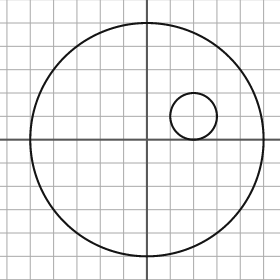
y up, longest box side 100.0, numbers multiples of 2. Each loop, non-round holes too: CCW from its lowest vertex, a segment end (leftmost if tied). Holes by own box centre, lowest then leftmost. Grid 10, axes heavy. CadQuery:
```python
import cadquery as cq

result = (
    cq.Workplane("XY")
    .moveTo(0.0, 0.0)
    .circle(50.0)
    .moveTo(20.0, 10.0)
    .circle(10.0)
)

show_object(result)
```